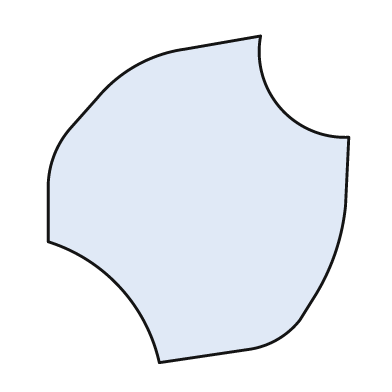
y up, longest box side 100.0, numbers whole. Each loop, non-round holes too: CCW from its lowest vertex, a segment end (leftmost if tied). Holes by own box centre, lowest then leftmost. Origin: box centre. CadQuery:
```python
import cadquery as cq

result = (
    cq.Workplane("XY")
    .moveTo(-12.0, -50.0)
    .lineTo(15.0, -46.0)
    .threePointArc((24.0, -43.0), (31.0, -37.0))
    .lineTo(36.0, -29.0)
    .threePointArc((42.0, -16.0), (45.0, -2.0))
    .lineTo(46.0, 19.0)
    .threePointArc((25.0, 28.0), (19.0, 50.0))
    .lineTo(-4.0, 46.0)
    .threePointArc((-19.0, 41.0), (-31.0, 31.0))
    .lineTo(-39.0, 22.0)
    .threePointArc((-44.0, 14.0), (-46.0, 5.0))
    .lineTo(-46.0, -13.0)
    .threePointArc((-24.0, -27.0), (-12.0, -50.0))
    .close()
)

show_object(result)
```